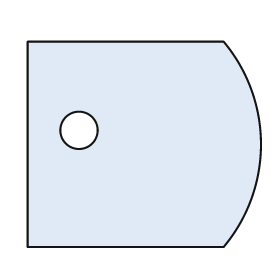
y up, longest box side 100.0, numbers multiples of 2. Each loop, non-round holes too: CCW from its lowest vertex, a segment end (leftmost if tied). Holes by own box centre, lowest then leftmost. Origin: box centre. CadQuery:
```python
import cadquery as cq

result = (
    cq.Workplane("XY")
    .moveTo(-50.0, -44.0)
    .lineTo(34.0, -44.0)
    .threePointArc((50.0, 0.0), (34.0, 44.0))
    .lineTo(-50.0, 44.0)
    .close()
    .moveTo(-28.0, 6.0)
    .circle(8.0)
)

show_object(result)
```